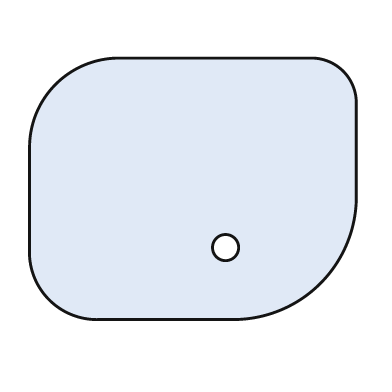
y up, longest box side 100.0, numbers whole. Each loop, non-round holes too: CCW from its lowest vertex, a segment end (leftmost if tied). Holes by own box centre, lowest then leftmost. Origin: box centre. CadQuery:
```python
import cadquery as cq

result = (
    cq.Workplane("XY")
    .moveTo(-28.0, -40.0)
    .lineTo(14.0, -40.0)
    .threePointArc((39.0, -29.0), (50.0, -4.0))
    .lineTo(50.0, 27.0)
    .threePointArc((46.0, 36.0), (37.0, 40.0))
    .lineTo(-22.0, 40.0)
    .threePointArc((-42.0, 32.0), (-50.0, 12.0))
    .lineTo(-50.0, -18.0)
    .threePointArc((-44.0, -34.0), (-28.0, -40.0))
    .close()
    .moveTo(10.0, -18.0)
    .circle(4.0)
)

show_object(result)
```